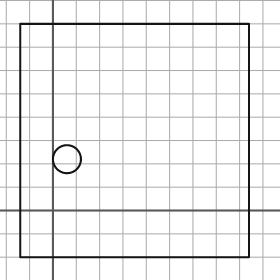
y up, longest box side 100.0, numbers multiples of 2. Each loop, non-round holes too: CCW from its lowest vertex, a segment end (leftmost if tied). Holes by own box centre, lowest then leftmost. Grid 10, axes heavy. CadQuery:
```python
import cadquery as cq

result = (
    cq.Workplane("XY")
    .moveTo(-14.0, -20.0)
    .lineTo(84.0, -20.0)
    .lineTo(84.0, 80.0)
    .lineTo(-14.0, 80.0)
    .close()
    .moveTo(6.0, 22.0)
    .circle(6.0)
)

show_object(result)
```